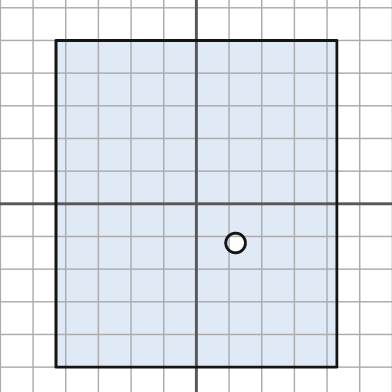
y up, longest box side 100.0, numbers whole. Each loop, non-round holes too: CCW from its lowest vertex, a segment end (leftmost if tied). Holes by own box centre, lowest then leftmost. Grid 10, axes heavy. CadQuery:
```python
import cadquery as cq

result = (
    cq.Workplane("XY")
    .moveTo(-43.0, -50.0)
    .lineTo(43.0, -50.0)
    .lineTo(43.0, 50.0)
    .lineTo(-43.0, 50.0)
    .close()
    .moveTo(12.0, -12.0)
    .circle(3.0)
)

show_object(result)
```